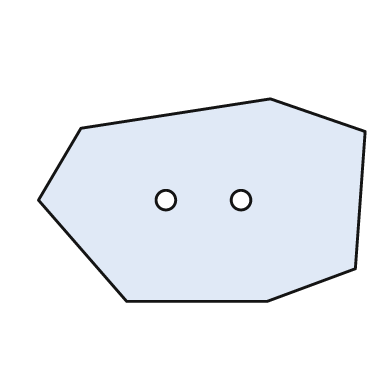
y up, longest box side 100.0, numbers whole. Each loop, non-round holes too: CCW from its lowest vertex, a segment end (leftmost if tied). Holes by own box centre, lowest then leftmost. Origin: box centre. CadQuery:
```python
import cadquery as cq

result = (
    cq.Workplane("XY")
    .moveTo(-23.0, -31.0)
    .lineTo(20.0, -31.0)
    .lineTo(47.0, -21.0)
    .lineTo(50.0, 21.0)
    .lineTo(21.0, 31.0)
    .lineTo(-37.0, 22.0)
    .lineTo(-50.0, 0.0)
    .close()
    .moveTo(-11.0, 0.0)
    .circle(3.0)
    .moveTo(12.0, 0.0)
    .circle(3.0)
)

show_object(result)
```